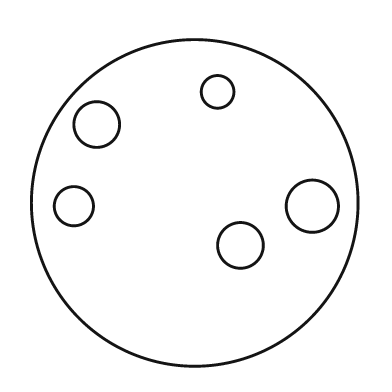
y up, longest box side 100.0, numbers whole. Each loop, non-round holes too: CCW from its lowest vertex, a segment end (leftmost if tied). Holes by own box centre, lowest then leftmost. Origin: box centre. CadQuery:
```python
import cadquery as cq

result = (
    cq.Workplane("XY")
    .moveTo(0.0, 0.0)
    .circle(50.0)
    .moveTo(14.0, -13.0)
    .circle(7.0)
    .moveTo(-37.0, -1.0)
    .circle(6.0)
    .moveTo(36.0, -1.0)
    .circle(8.0)
    .moveTo(-30.0, 24.0)
    .circle(7.0)
    .moveTo(7.0, 34.0)
    .circle(5.0)
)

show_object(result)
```